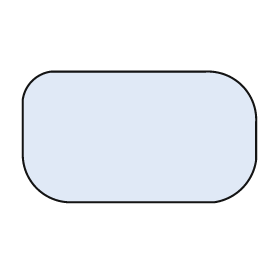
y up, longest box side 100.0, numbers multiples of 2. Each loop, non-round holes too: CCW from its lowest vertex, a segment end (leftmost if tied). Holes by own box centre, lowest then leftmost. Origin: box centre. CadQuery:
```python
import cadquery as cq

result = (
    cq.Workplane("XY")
    .moveTo(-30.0, -28.0)
    .lineTo(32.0, -28.0)
    .threePointArc((44.0, -22.0), (50.0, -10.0))
    .lineTo(50.0, 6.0)
    .threePointArc((44.0, 22.0), (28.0, 28.0))
    .lineTo(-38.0, 28.0)
    .threePointArc((-46.0, 24.0), (-50.0, 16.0))
    .lineTo(-50.0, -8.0)
    .threePointArc((-44.0, -22.0), (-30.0, -28.0))
    .close()
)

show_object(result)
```